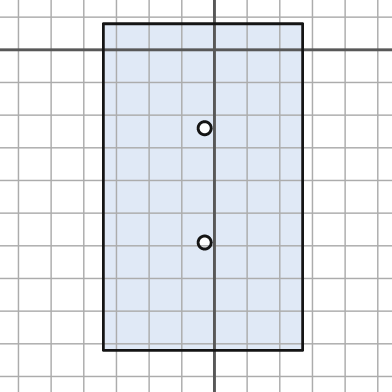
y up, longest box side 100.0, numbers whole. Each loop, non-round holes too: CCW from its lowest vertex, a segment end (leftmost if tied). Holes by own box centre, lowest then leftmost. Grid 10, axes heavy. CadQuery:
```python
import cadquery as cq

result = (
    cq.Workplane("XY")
    .moveTo(-34.0, -92.0)
    .lineTo(27.0, -92.0)
    .lineTo(27.0, 8.0)
    .lineTo(-34.0, 8.0)
    .close()
    .moveTo(-3.0, -59.0)
    .circle(2.0)
    .moveTo(-3.0, -24.0)
    .circle(2.0)
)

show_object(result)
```